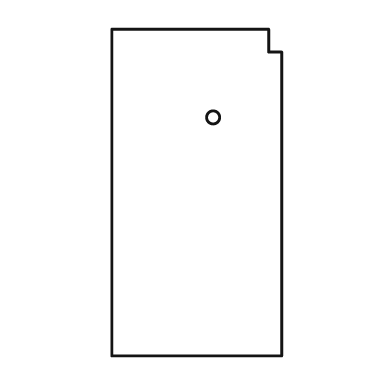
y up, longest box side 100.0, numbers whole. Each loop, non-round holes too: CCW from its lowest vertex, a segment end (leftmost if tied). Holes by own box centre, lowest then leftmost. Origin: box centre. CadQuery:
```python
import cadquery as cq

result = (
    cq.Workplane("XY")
    .moveTo(-26.0, -50.0)
    .lineTo(26.0, -50.0)
    .lineTo(26.0, 43.0)
    .lineTo(22.0, 43.0)
    .lineTo(22.0, 50.0)
    .lineTo(-26.0, 50.0)
    .close()
    .moveTo(5.0, 23.0)
    .circle(2.0)
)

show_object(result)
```